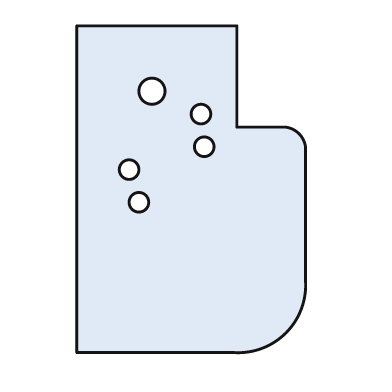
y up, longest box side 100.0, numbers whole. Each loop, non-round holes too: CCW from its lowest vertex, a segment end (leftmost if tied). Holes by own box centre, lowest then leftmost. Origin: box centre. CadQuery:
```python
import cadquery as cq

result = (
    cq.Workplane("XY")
    .moveTo(-35.0, -50.0)
    .lineTo(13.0, -50.0)
    .threePointArc((29.0, -44.0), (35.0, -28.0))
    .lineTo(35.0, 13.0)
    .threePointArc((33.0, 17.0), (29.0, 19.0))
    .lineTo(14.0, 19.0)
    .lineTo(14.0, 50.0)
    .lineTo(-35.0, 50.0)
    .close()
    .moveTo(-16.0, -4.0)
    .circle(3.0)
    .moveTo(-19.0, 6.0)
    .circle(3.0)
    .moveTo(4.0, 13.0)
    .circle(3.0)
    .moveTo(3.0, 23.0)
    .circle(3.0)
    .moveTo(-12.0, 30.0)
    .circle(4.0)
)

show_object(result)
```